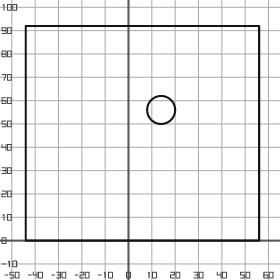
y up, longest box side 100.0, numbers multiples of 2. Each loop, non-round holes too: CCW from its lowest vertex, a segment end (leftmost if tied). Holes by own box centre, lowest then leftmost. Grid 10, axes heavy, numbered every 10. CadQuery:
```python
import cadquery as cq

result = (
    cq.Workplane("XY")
    .moveTo(-44.0, 0.0)
    .lineTo(56.0, 0.0)
    .lineTo(56.0, 92.0)
    .lineTo(-44.0, 92.0)
    .close()
    .moveTo(14.0, 56.0)
    .circle(6.0)
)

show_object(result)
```